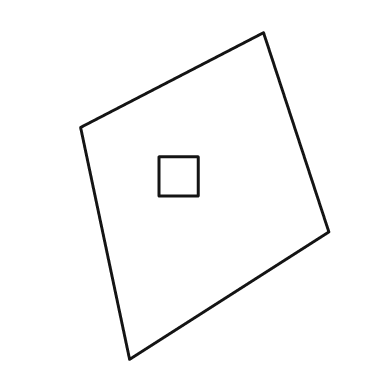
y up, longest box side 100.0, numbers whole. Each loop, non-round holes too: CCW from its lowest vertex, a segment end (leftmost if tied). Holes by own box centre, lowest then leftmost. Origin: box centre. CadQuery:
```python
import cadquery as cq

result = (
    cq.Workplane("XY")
    .moveTo(-23.0, -50.0)
    .lineTo(38.0, -11.0)
    .lineTo(18.0, 50.0)
    .lineTo(-38.0, 21.0)
    .close()
    .moveTo(-14.0, 0.0)
    .lineTo(-2.0, 0.0)
    .lineTo(-2.0, 12.0)
    .lineTo(-14.0, 12.0)
    .close()
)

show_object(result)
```